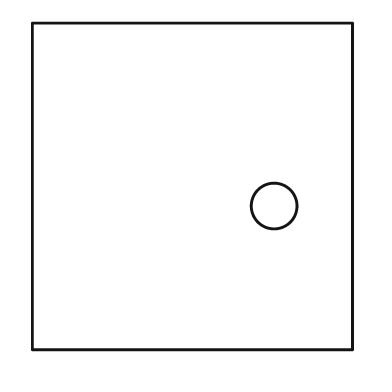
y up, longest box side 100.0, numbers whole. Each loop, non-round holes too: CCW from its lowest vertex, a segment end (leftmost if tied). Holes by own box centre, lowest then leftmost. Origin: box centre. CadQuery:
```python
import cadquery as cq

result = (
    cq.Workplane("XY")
    .moveTo(-49.0, -50.0)
    .lineTo(49.0, -50.0)
    .lineTo(49.0, 50.0)
    .lineTo(-49.0, 50.0)
    .close()
    .moveTo(25.0, -6.0)
    .circle(7.0)
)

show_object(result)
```